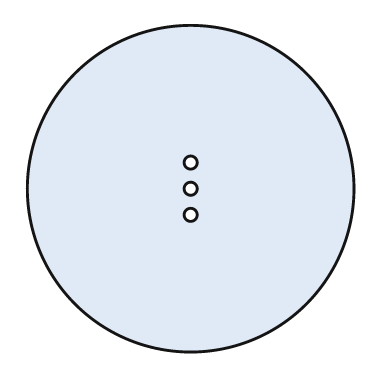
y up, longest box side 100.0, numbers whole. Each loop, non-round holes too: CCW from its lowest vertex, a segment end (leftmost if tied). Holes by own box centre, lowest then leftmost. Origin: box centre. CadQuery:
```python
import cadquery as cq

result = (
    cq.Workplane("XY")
    .moveTo(0.0, 0.0)
    .circle(50.0)
    .moveTo(0.0, -8.0)
    .circle(2.0)
    .moveTo(0.0, 0.0)
    .circle(2.0)
    .moveTo(0.0, 8.0)
    .circle(2.0)
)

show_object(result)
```